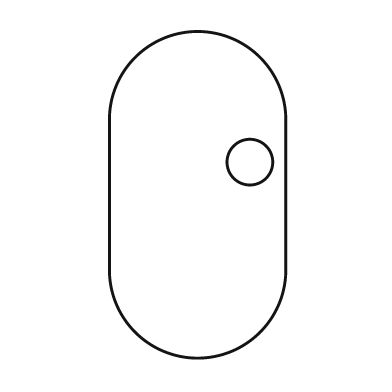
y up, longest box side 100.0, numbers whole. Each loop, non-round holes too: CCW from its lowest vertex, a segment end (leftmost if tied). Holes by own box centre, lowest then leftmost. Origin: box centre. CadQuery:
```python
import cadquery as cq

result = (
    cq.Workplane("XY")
    .moveTo(-27.0, -23.0)
    .threePointArc((0.0, -50.0), (27.0, -23.0))
    .lineTo(27.0, 23.0)
    .threePointArc((0.0, 50.0), (-27.0, 23.0))
    .close()
    .moveTo(16.0, 10.0)
    .circle(7.0)
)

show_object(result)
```